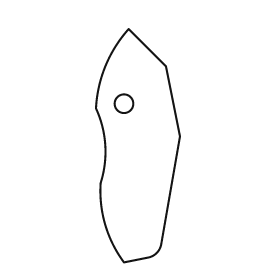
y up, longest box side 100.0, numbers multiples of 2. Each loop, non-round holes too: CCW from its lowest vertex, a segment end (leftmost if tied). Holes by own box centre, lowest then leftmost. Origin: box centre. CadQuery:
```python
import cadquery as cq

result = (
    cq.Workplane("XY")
    .moveTo(-6.0, -50.0)
    .lineTo(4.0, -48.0)
    .threePointArc((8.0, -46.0), (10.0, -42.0))
    .lineTo(18.0, 4.0)
    .lineTo(12.0, 34.0)
    .lineTo(-4.0, 50.0)
    .threePointArc((-14.0, 34.0), (-18.0, 16.0))
    .threePointArc((-14.0, 0.0), (-16.0, -16.0))
    .threePointArc((-14.0, -34.0), (-6.0, -50.0))
    .close()
    .moveTo(-6.0, 18.0)
    .circle(4.0)
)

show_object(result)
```